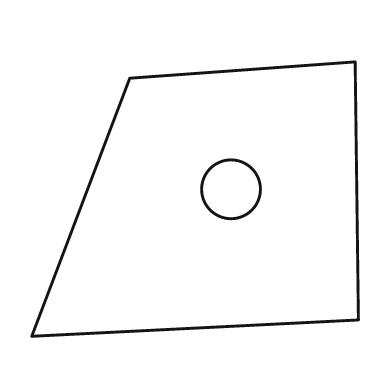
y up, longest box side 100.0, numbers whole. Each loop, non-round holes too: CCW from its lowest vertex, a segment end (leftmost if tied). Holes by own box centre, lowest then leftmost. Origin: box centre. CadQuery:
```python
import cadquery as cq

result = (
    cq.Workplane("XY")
    .moveTo(-50.0, -42.0)
    .lineTo(50.0, -37.0)
    .lineTo(49.0, 42.0)
    .lineTo(-20.0, 37.0)
    .close()
    .moveTo(11.0, 3.0)
    .circle(9.0)
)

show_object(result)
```